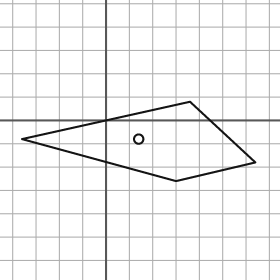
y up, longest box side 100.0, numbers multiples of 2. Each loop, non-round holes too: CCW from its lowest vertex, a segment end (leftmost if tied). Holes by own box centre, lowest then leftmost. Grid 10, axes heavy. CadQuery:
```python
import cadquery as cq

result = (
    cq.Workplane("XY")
    .moveTo(30.0, -26.0)
    .lineTo(64.0, -18.0)
    .lineTo(36.0, 8.0)
    .lineTo(-36.0, -8.0)
    .close()
    .moveTo(14.0, -8.0)
    .circle(2.0)
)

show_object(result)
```